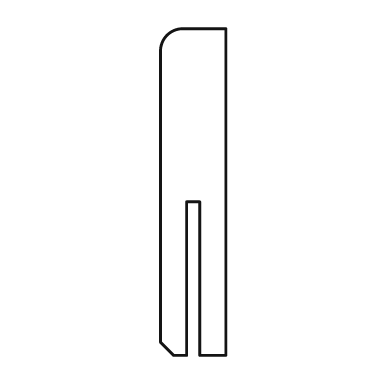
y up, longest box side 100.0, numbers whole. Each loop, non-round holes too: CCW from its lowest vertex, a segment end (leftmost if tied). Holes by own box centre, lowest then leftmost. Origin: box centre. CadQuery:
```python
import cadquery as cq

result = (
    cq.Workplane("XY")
    .moveTo(-6.0, -50.0)
    .lineTo(-2.0, -50.0)
    .lineTo(-2.0, -3.0)
    .lineTo(2.0, -3.0)
    .lineTo(2.0, -50.0)
    .lineTo(10.0, -50.0)
    .lineTo(10.0, 50.0)
    .lineTo(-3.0, 50.0)
    .threePointArc((-8.0, 48.0), (-10.0, 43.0))
    .lineTo(-10.0, -46.0)
    .close()
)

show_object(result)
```